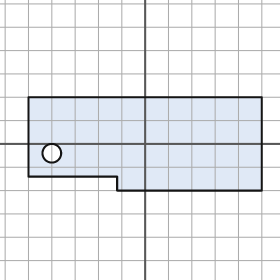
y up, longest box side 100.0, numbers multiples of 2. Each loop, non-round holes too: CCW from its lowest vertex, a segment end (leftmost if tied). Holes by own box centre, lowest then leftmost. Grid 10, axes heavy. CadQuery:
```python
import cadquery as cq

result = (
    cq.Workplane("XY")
    .moveTo(-12.0, -20.0)
    .lineTo(50.0, -20.0)
    .lineTo(50.0, 20.0)
    .lineTo(-50.0, 20.0)
    .lineTo(-50.0, -14.0)
    .lineTo(-12.0, -14.0)
    .close()
    .moveTo(-40.0, -4.0)
    .circle(4.0)
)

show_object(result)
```